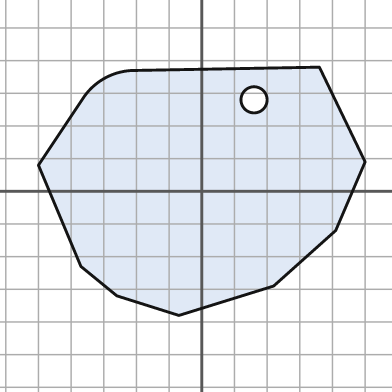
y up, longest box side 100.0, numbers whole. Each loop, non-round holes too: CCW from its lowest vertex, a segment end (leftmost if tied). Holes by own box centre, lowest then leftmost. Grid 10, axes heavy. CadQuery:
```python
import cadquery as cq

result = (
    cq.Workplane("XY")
    .moveTo(-7.0, -38.0)
    .lineTo(22.0, -29.0)
    .lineTo(41.0, -12.0)
    .lineTo(50.0, 9.0)
    .lineTo(36.0, 38.0)
    .lineTo(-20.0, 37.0)
    .threePointArc((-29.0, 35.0), (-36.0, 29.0))
    .lineTo(-50.0, 8.0)
    .lineTo(-37.0, -23.0)
    .lineTo(-26.0, -32.0)
    .close()
    .moveTo(16.0, 28.0)
    .circle(4.0)
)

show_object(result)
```